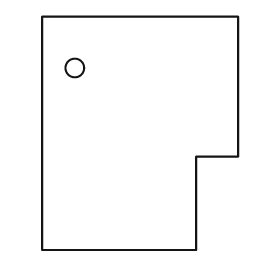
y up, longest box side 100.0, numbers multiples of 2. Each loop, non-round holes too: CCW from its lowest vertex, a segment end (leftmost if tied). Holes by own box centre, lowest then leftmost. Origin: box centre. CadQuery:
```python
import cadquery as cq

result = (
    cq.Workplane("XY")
    .moveTo(-42.0, -50.0)
    .lineTo(24.0, -50.0)
    .lineTo(24.0, -10.0)
    .lineTo(42.0, -10.0)
    .lineTo(42.0, 50.0)
    .lineTo(-42.0, 50.0)
    .close()
    .moveTo(-28.0, 28.0)
    .circle(4.0)
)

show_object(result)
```